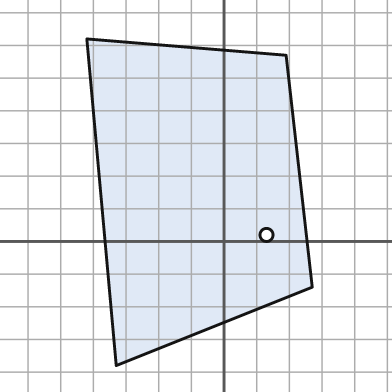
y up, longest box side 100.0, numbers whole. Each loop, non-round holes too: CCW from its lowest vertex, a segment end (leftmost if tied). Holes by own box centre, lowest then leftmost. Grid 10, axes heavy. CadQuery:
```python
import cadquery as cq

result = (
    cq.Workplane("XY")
    .moveTo(-33.0, -38.0)
    .lineTo(27.0, -14.0)
    .lineTo(19.0, 57.0)
    .lineTo(-42.0, 62.0)
    .close()
    .moveTo(13.0, 2.0)
    .circle(2.0)
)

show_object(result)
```